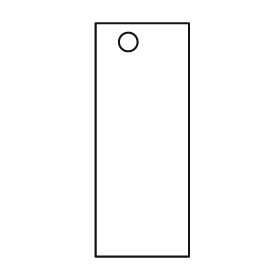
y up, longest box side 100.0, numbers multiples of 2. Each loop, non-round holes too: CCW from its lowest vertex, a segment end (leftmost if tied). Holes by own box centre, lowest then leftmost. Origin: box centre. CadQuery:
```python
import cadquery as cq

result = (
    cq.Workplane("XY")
    .moveTo(-20.0, -50.0)
    .lineTo(20.0, -50.0)
    .lineTo(20.0, 50.0)
    .lineTo(-20.0, 50.0)
    .close()
    .moveTo(-6.0, 42.0)
    .circle(4.0)
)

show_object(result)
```